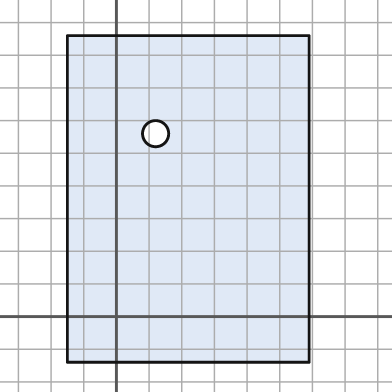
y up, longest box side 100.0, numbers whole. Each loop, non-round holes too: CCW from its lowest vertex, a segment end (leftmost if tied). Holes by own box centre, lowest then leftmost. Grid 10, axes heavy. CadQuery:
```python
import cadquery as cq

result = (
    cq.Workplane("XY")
    .moveTo(-15.0, -14.0)
    .lineTo(59.0, -14.0)
    .lineTo(59.0, 86.0)
    .lineTo(-15.0, 86.0)
    .close()
    .moveTo(12.0, 56.0)
    .circle(4.0)
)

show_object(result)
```